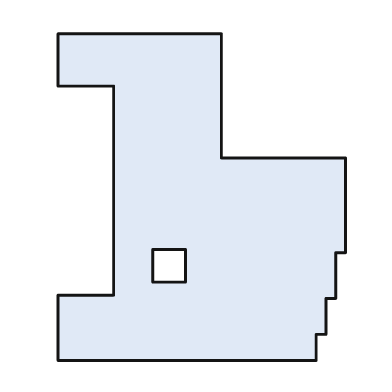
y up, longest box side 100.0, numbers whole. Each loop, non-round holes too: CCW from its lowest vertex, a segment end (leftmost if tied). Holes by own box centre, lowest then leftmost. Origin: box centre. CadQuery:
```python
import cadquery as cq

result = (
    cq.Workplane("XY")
    .moveTo(-44.0, -50.0)
    .lineTo(35.0, -50.0)
    .lineTo(35.0, -42.0)
    .lineTo(38.0, -42.0)
    .lineTo(38.0, -31.0)
    .lineTo(41.0, -31.0)
    .lineTo(41.0, -17.0)
    .lineTo(44.0, -17.0)
    .lineTo(44.0, 12.0)
    .lineTo(6.0, 12.0)
    .lineTo(6.0, 50.0)
    .lineTo(-44.0, 50.0)
    .lineTo(-44.0, 34.0)
    .lineTo(-27.0, 34.0)
    .lineTo(-27.0, -30.0)
    .lineTo(-44.0, -30.0)
    .close()
    .moveTo(-15.0, -26.0)
    .lineTo(-5.0, -26.0)
    .lineTo(-5.0, -16.0)
    .lineTo(-15.0, -16.0)
    .close()
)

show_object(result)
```